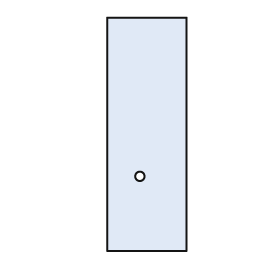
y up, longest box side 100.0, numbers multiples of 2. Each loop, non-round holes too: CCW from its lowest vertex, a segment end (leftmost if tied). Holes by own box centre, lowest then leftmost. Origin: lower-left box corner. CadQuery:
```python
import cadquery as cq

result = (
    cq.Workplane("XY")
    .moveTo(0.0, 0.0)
    .lineTo(34.0, 0.0)
    .lineTo(34.0, 100.0)
    .lineTo(0.0, 100.0)
    .close()
    .moveTo(14.0, 32.0)
    .circle(2.0)
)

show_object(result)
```